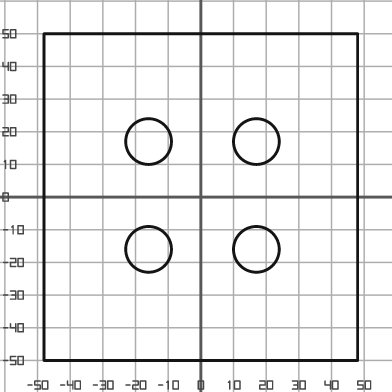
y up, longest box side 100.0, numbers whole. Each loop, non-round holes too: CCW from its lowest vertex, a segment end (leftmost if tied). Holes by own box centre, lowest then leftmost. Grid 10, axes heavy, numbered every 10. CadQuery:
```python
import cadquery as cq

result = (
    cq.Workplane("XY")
    .moveTo(-48.0, -50.0)
    .lineTo(48.0, -50.0)
    .lineTo(48.0, 50.0)
    .lineTo(-48.0, 50.0)
    .close()
    .moveTo(-16.0, -16.0)
    .circle(7.0)
    .moveTo(17.0, -16.0)
    .circle(7.0)
    .moveTo(-16.0, 17.0)
    .circle(7.0)
    .moveTo(17.0, 17.0)
    .circle(7.0)
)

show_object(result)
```